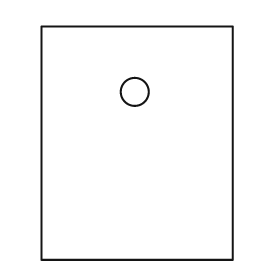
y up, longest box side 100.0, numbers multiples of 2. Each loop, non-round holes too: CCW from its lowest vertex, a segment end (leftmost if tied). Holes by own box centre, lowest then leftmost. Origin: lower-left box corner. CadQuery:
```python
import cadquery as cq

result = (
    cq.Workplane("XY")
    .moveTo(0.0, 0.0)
    .lineTo(82.0, 0.0)
    .lineTo(82.0, 100.0)
    .lineTo(0.0, 100.0)
    .close()
    .moveTo(40.0, 72.0)
    .circle(6.0)
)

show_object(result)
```